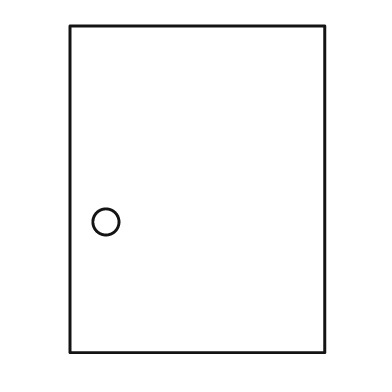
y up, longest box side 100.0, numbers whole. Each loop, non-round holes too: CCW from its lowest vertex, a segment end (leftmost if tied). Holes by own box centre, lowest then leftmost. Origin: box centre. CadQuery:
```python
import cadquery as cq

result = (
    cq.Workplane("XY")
    .moveTo(-39.0, -50.0)
    .lineTo(39.0, -50.0)
    .lineTo(39.0, 50.0)
    .lineTo(-39.0, 50.0)
    .close()
    .moveTo(-28.0, -10.0)
    .circle(4.0)
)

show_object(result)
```